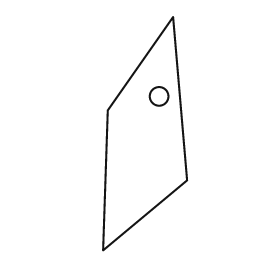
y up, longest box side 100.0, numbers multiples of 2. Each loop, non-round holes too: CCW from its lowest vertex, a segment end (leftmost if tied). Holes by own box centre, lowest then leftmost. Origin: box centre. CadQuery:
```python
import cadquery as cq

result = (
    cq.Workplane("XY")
    .moveTo(-18.0, -50.0)
    .lineTo(18.0, -20.0)
    .lineTo(12.0, 50.0)
    .lineTo(-16.0, 10.0)
    .close()
    .moveTo(6.0, 16.0)
    .circle(4.0)
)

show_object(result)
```